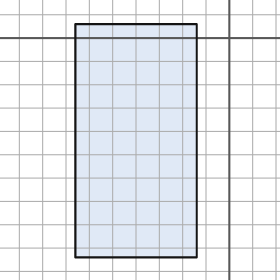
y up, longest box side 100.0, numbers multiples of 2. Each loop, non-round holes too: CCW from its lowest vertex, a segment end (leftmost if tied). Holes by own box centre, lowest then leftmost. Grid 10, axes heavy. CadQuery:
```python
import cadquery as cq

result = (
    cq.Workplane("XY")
    .moveTo(-66.0, -94.0)
    .lineTo(-14.0, -94.0)
    .lineTo(-14.0, 6.0)
    .lineTo(-66.0, 6.0)
    .close()
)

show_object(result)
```